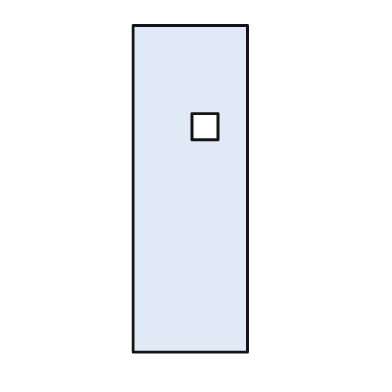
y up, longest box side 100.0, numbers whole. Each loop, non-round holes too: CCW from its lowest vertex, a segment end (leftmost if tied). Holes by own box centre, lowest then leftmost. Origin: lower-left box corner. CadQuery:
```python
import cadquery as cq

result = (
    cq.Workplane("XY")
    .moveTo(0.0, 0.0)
    .lineTo(35.0, 0.0)
    .lineTo(35.0, 100.0)
    .lineTo(0.0, 100.0)
    .close()
    .moveTo(18.0, 65.0)
    .lineTo(26.0, 65.0)
    .lineTo(26.0, 73.0)
    .lineTo(18.0, 73.0)
    .close()
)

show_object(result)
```